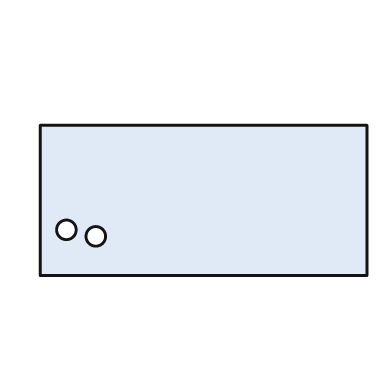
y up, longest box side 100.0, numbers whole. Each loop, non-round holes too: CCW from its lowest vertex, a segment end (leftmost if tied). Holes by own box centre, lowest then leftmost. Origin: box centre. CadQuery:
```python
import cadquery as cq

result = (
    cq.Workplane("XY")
    .moveTo(-50.0, -23.0)
    .lineTo(50.0, -23.0)
    .lineTo(50.0, 23.0)
    .lineTo(-50.0, 23.0)
    .close()
    .moveTo(-33.0, -11.0)
    .circle(3.0)
    .moveTo(-42.0, -9.0)
    .circle(3.0)
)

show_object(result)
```